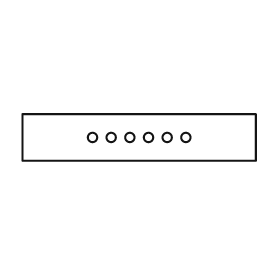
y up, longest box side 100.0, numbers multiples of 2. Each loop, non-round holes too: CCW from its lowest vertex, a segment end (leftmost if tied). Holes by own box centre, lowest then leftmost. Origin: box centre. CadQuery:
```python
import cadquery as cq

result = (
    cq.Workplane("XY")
    .moveTo(-50.0, -10.0)
    .lineTo(50.0, -10.0)
    .lineTo(50.0, 10.0)
    .lineTo(-50.0, 10.0)
    .close()
    .moveTo(-20.0, 0.0)
    .circle(2.0)
    .moveTo(-12.0, 0.0)
    .circle(2.0)
    .moveTo(-4.0, 0.0)
    .circle(2.0)
    .moveTo(4.0, 0.0)
    .circle(2.0)
    .moveTo(12.0, 0.0)
    .circle(2.0)
    .moveTo(20.0, 0.0)
    .circle(2.0)
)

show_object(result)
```